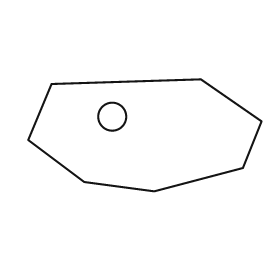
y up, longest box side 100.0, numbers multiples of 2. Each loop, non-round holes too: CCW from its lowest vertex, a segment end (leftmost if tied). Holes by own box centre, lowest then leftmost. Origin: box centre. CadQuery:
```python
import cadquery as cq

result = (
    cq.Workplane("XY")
    .moveTo(4.0, -24.0)
    .lineTo(42.0, -14.0)
    .lineTo(50.0, 6.0)
    .lineTo(24.0, 24.0)
    .lineTo(-40.0, 22.0)
    .lineTo(-50.0, -2.0)
    .lineTo(-26.0, -20.0)
    .close()
    .moveTo(-14.0, 8.0)
    .circle(6.0)
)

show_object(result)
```